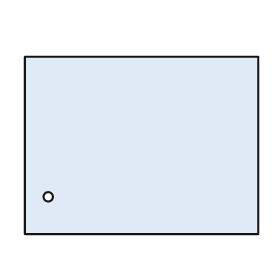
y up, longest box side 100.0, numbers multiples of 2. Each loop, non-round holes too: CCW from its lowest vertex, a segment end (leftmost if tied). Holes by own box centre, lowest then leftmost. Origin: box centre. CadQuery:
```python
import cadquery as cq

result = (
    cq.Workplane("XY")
    .moveTo(-50.0, -38.0)
    .lineTo(50.0, -38.0)
    .lineTo(50.0, 38.0)
    .lineTo(-50.0, 38.0)
    .close()
    .moveTo(-40.0, -22.0)
    .circle(2.0)
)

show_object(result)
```